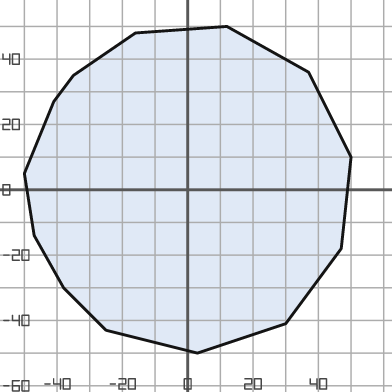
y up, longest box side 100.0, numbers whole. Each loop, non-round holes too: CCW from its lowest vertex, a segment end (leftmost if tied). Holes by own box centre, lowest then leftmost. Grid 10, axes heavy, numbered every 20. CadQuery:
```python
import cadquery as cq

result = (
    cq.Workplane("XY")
    .moveTo(3.0, -50.0)
    .lineTo(30.0, -41.0)
    .lineTo(47.0, -18.0)
    .lineTo(50.0, 10.0)
    .lineTo(37.0, 36.0)
    .lineTo(12.0, 50.0)
    .lineTo(-16.0, 48.0)
    .lineTo(-35.0, 35.0)
    .lineTo(-41.0, 27.0)
    .lineTo(-50.0, 5.0)
    .lineTo(-47.0, -14.0)
    .lineTo(-38.0, -30.0)
    .lineTo(-25.0, -43.0)
    .close()
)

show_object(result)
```